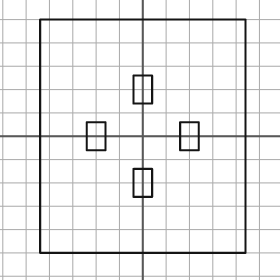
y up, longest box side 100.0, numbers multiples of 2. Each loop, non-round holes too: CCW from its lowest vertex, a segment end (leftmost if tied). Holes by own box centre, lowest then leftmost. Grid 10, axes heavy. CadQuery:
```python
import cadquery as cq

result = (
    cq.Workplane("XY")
    .moveTo(-44.0, -50.0)
    .lineTo(44.0, -50.0)
    .lineTo(44.0, 50.0)
    .lineTo(-44.0, 50.0)
    .close()
    .moveTo(-4.0, -26.0)
    .lineTo(4.0, -26.0)
    .lineTo(4.0, -14.0)
    .lineTo(-4.0, -14.0)
    .close()
    .moveTo(-24.0, -6.0)
    .lineTo(-16.0, -6.0)
    .lineTo(-16.0, 6.0)
    .lineTo(-24.0, 6.0)
    .close()
    .moveTo(16.0, -6.0)
    .lineTo(24.0, -6.0)
    .lineTo(24.0, 6.0)
    .lineTo(16.0, 6.0)
    .close()
    .moveTo(-4.0, 14.0)
    .lineTo(4.0, 14.0)
    .lineTo(4.0, 26.0)
    .lineTo(-4.0, 26.0)
    .close()
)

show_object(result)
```